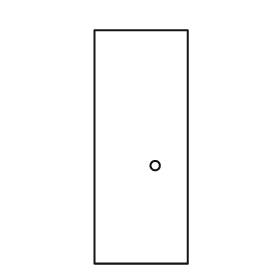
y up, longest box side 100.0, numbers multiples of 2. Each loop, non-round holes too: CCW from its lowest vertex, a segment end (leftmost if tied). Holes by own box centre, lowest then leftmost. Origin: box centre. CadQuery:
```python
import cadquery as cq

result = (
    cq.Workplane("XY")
    .moveTo(-20.0, -50.0)
    .lineTo(20.0, -50.0)
    .lineTo(20.0, 50.0)
    .lineTo(-20.0, 50.0)
    .close()
    .moveTo(6.0, -8.0)
    .circle(2.0)
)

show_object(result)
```